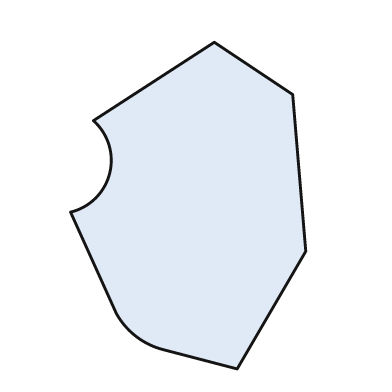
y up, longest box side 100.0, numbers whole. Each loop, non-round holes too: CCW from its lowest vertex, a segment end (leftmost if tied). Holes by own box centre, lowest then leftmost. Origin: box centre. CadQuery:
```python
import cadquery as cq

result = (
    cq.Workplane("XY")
    .moveTo(15.0, -50.0)
    .lineTo(36.0, -14.0)
    .lineTo(32.0, 34.0)
    .lineTo(8.0, 50.0)
    .lineTo(-29.0, 26.0)
    .threePointArc((-24.0, 10.0), (-36.0, -2.0))
    .lineTo(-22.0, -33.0)
    .threePointArc((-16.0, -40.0), (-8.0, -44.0))
    .close()
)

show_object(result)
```